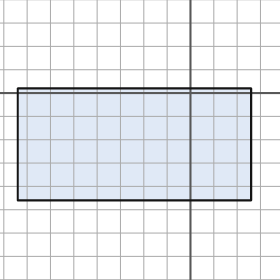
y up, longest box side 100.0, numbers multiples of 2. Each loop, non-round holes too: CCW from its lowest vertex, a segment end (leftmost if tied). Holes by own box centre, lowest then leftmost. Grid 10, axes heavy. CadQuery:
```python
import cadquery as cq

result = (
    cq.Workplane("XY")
    .moveTo(-74.0, -46.0)
    .lineTo(26.0, -46.0)
    .lineTo(26.0, 2.0)
    .lineTo(-74.0, 2.0)
    .close()
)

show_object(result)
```